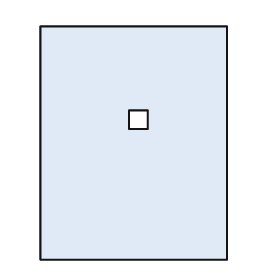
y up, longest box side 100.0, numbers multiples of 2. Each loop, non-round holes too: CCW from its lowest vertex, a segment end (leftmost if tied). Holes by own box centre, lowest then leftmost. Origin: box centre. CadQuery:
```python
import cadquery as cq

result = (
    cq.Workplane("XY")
    .moveTo(-40.0, -50.0)
    .lineTo(40.0, -50.0)
    .lineTo(40.0, 50.0)
    .lineTo(-40.0, 50.0)
    .close()
    .moveTo(-2.0, 6.0)
    .lineTo(6.0, 6.0)
    .lineTo(6.0, 14.0)
    .lineTo(-2.0, 14.0)
    .close()
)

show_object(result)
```